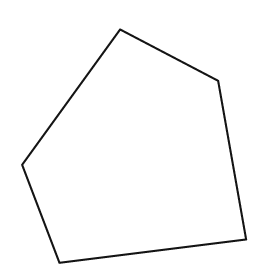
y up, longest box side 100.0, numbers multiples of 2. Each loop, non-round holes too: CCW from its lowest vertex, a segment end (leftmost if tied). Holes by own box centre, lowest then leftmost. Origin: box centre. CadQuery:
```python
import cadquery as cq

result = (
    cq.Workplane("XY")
    .moveTo(-32.0, -50.0)
    .lineTo(48.0, -40.0)
    .lineTo(36.0, 28.0)
    .lineTo(-6.0, 50.0)
    .lineTo(-48.0, -8.0)
    .close()
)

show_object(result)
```